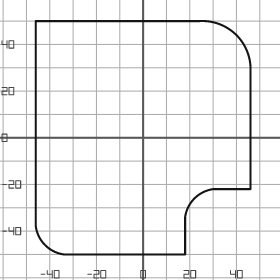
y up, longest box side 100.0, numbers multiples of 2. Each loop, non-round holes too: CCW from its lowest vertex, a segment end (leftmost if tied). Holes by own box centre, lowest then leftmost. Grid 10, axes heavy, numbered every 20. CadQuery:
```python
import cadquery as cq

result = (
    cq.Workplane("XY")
    .moveTo(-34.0, -50.0)
    .lineTo(18.0, -50.0)
    .lineTo(18.0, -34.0)
    .threePointArc((22.0, -26.0), (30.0, -22.0))
    .lineTo(46.0, -22.0)
    .lineTo(46.0, 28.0)
    .threePointArc((40.0, 44.0), (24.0, 50.0))
    .lineTo(-46.0, 50.0)
    .lineTo(-46.0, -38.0)
    .threePointArc((-42.0, -46.0), (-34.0, -50.0))
    .close()
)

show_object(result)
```